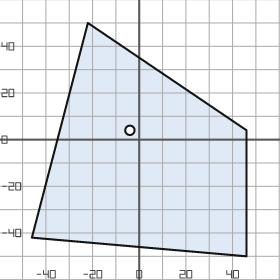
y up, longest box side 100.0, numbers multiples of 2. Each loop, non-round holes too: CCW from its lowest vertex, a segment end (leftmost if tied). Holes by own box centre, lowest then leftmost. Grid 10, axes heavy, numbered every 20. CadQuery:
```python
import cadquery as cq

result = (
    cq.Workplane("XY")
    .moveTo(46.0, -50.0)
    .lineTo(46.0, 4.0)
    .lineTo(-22.0, 50.0)
    .lineTo(-46.0, -42.0)
    .close()
    .moveTo(-4.0, 4.0)
    .circle(2.0)
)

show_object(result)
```